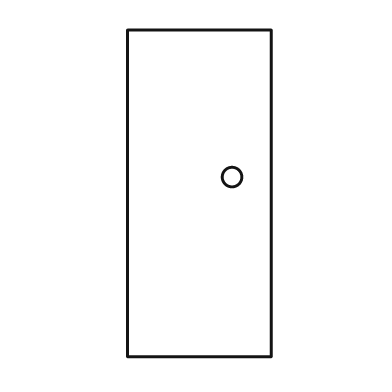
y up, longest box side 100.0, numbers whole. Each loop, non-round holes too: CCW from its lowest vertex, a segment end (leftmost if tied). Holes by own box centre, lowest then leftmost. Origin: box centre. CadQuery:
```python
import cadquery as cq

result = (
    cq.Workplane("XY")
    .moveTo(-22.0, -50.0)
    .lineTo(22.0, -50.0)
    .lineTo(22.0, 50.0)
    .lineTo(-22.0, 50.0)
    .close()
    .moveTo(10.0, 5.0)
    .circle(3.0)
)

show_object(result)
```